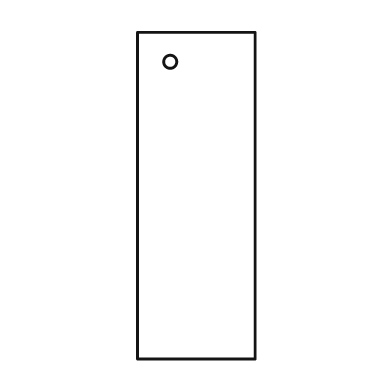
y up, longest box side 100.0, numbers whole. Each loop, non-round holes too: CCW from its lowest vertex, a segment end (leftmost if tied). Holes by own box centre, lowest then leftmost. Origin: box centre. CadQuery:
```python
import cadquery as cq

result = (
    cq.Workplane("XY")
    .moveTo(-18.0, -50.0)
    .lineTo(18.0, -50.0)
    .lineTo(18.0, 50.0)
    .lineTo(-18.0, 50.0)
    .close()
    .moveTo(-8.0, 41.0)
    .circle(2.0)
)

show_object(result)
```